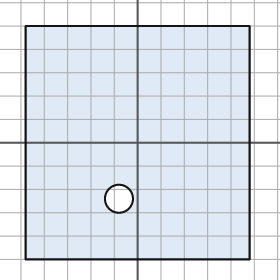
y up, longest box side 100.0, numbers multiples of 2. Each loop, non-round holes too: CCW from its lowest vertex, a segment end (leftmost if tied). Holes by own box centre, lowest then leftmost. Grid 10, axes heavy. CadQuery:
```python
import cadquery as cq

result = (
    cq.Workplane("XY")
    .moveTo(-48.0, -50.0)
    .lineTo(48.0, -50.0)
    .lineTo(48.0, 50.0)
    .lineTo(-48.0, 50.0)
    .close()
    .moveTo(-8.0, -24.0)
    .circle(6.0)
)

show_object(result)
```